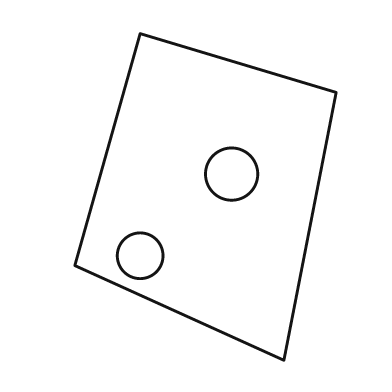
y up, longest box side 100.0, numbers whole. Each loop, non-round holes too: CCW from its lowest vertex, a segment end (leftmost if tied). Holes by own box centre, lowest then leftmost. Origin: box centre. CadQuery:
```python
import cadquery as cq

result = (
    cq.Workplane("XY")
    .moveTo(24.0, -50.0)
    .lineTo(40.0, 32.0)
    .lineTo(-20.0, 50.0)
    .lineTo(-40.0, -21.0)
    .close()
    .moveTo(-20.0, -18.0)
    .circle(7.0)
    .moveTo(8.0, 7.0)
    .circle(8.0)
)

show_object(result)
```